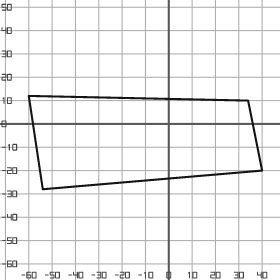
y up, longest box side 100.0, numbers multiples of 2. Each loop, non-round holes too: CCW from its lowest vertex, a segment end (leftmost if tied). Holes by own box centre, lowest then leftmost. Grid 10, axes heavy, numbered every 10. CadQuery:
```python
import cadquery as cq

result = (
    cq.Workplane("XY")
    .moveTo(-54.0, -28.0)
    .lineTo(40.0, -20.0)
    .lineTo(34.0, 10.0)
    .lineTo(-60.0, 12.0)
    .close()
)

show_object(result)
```